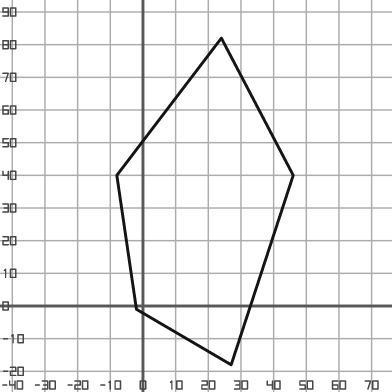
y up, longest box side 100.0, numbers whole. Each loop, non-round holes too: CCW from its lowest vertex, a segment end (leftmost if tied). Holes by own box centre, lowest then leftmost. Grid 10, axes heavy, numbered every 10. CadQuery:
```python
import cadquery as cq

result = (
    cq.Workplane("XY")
    .moveTo(27.0, -18.0)
    .lineTo(46.0, 40.0)
    .lineTo(24.0, 82.0)
    .lineTo(-8.0, 40.0)
    .lineTo(-2.0, -1.0)
    .close()
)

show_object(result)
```